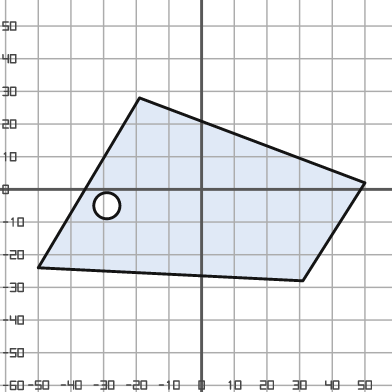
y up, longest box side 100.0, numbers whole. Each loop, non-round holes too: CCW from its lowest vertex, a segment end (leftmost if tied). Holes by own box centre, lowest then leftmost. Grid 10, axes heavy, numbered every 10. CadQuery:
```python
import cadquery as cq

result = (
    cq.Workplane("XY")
    .moveTo(31.0, -28.0)
    .lineTo(50.0, 2.0)
    .lineTo(-19.0, 28.0)
    .lineTo(-50.0, -24.0)
    .close()
    .moveTo(-29.0, -5.0)
    .circle(4.0)
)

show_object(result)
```